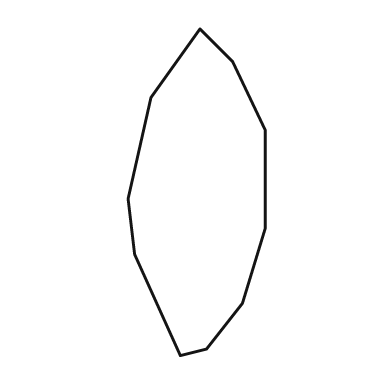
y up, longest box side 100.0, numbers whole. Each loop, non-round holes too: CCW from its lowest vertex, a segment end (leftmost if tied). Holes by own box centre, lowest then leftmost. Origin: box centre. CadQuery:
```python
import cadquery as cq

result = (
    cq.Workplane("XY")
    .moveTo(-5.0, -50.0)
    .lineTo(3.0, -48.0)
    .lineTo(14.0, -34.0)
    .lineTo(21.0, -11.0)
    .lineTo(21.0, 19.0)
    .lineTo(11.0, 40.0)
    .lineTo(1.0, 50.0)
    .lineTo(-14.0, 29.0)
    .lineTo(-21.0, -2.0)
    .lineTo(-19.0, -19.0)
    .close()
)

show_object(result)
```